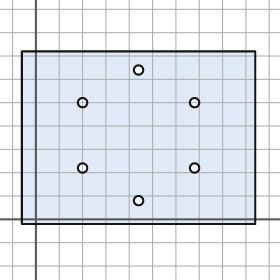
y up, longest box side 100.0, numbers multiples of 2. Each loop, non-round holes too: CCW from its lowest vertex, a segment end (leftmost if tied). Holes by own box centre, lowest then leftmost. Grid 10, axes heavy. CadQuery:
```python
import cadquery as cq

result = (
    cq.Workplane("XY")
    .moveTo(-6.0, -2.0)
    .lineTo(94.0, -2.0)
    .lineTo(94.0, 72.0)
    .lineTo(-6.0, 72.0)
    .close()
    .moveTo(44.0, 8.0)
    .circle(2.0)
    .moveTo(20.0, 22.0)
    .circle(2.0)
    .moveTo(68.0, 22.0)
    .circle(2.0)
    .moveTo(20.0, 50.0)
    .circle(2.0)
    .moveTo(68.0, 50.0)
    .circle(2.0)
    .moveTo(44.0, 64.0)
    .circle(2.0)
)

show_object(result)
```